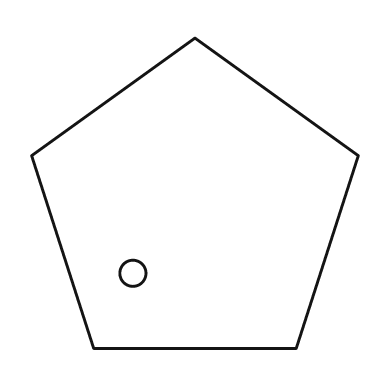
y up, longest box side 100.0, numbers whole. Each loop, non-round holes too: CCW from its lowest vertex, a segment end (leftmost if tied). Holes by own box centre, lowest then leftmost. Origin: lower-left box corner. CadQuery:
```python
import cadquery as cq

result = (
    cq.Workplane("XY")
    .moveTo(19.0, 0.0)
    .lineTo(81.0, 0.0)
    .lineTo(100.0, 59.0)
    .lineTo(50.0, 95.0)
    .lineTo(0.0, 59.0)
    .close()
    .moveTo(31.0, 23.0)
    .circle(4.0)
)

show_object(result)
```